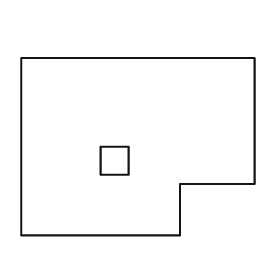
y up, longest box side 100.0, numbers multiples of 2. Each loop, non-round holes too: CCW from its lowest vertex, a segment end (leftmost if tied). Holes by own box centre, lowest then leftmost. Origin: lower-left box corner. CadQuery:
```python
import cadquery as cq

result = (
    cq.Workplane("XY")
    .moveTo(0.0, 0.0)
    .lineTo(68.0, 0.0)
    .lineTo(68.0, 22.0)
    .lineTo(100.0, 22.0)
    .lineTo(100.0, 76.0)
    .lineTo(0.0, 76.0)
    .close()
    .moveTo(34.0, 26.0)
    .lineTo(46.0, 26.0)
    .lineTo(46.0, 38.0)
    .lineTo(34.0, 38.0)
    .close()
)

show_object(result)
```